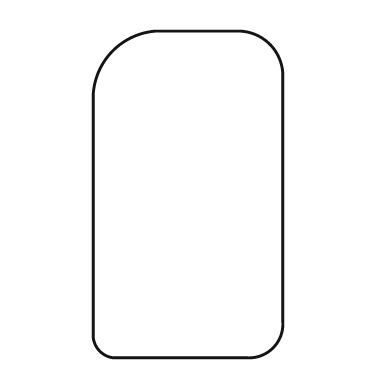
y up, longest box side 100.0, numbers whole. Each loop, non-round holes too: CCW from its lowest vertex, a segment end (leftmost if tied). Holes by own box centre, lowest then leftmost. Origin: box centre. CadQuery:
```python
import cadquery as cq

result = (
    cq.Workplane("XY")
    .moveTo(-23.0, -50.0)
    .lineTo(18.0, -50.0)
    .threePointArc((26.0, -47.0), (29.0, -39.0))
    .lineTo(29.0, 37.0)
    .threePointArc((25.0, 46.0), (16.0, 50.0))
    .lineTo(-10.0, 50.0)
    .threePointArc((-23.0, 44.0), (-29.0, 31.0))
    .lineTo(-29.0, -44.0)
    .threePointArc((-27.0, -48.0), (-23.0, -50.0))
    .close()
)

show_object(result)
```